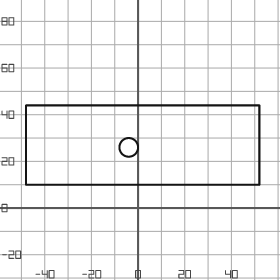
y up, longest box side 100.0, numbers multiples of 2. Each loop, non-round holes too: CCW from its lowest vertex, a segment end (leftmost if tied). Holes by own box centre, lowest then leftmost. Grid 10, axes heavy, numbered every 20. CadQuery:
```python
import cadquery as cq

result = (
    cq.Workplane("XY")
    .moveTo(-48.0, 10.0)
    .lineTo(52.0, 10.0)
    .lineTo(52.0, 44.0)
    .lineTo(-48.0, 44.0)
    .close()
    .moveTo(-4.0, 26.0)
    .circle(4.0)
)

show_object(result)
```